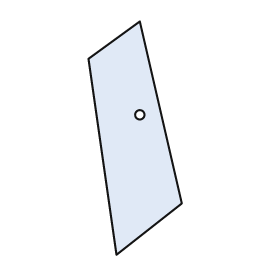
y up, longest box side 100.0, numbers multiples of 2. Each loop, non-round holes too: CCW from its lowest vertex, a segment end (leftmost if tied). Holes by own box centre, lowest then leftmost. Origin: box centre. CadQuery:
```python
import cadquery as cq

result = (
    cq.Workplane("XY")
    .moveTo(-8.0, -50.0)
    .lineTo(20.0, -28.0)
    .lineTo(2.0, 50.0)
    .lineTo(-20.0, 34.0)
    .close()
    .moveTo(2.0, 10.0)
    .circle(2.0)
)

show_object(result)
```